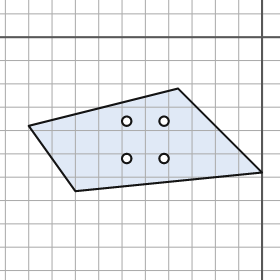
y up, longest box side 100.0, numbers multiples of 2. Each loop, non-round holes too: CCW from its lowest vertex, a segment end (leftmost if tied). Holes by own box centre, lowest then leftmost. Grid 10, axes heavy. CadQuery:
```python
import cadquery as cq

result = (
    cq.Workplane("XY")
    .moveTo(-80.0, -66.0)
    .lineTo(0.0, -58.0)
    .lineTo(-36.0, -22.0)
    .lineTo(-100.0, -38.0)
    .close()
    .moveTo(-58.0, -52.0)
    .circle(2.0)
    .moveTo(-42.0, -52.0)
    .circle(2.0)
    .moveTo(-58.0, -36.0)
    .circle(2.0)
    .moveTo(-42.0, -36.0)
    .circle(2.0)
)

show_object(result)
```